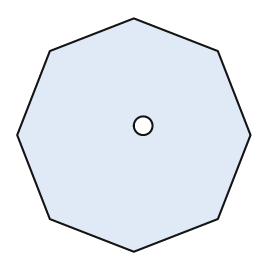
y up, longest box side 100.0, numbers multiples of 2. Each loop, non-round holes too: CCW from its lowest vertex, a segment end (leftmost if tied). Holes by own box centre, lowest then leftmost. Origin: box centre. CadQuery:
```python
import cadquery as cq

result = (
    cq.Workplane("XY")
    .moveTo(0.0, -50.0)
    .lineTo(36.0, -36.0)
    .lineTo(50.0, 0.0)
    .lineTo(36.0, 36.0)
    .lineTo(0.0, 50.0)
    .lineTo(-36.0, 36.0)
    .lineTo(-50.0, 0.0)
    .lineTo(-36.0, -36.0)
    .close()
    .moveTo(4.0, 4.0)
    .circle(4.0)
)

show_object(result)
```